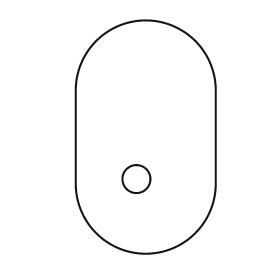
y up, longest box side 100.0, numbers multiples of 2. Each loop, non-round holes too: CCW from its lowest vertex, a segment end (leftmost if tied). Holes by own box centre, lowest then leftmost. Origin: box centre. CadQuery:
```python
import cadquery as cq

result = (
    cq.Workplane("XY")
    .moveTo(-30.0, -20.0)
    .threePointArc((0.0, -50.0), (30.0, -20.0))
    .lineTo(30.0, 20.0)
    .threePointArc((0.0, 50.0), (-30.0, 20.0))
    .close()
    .moveTo(-4.0, -18.0)
    .circle(6.0)
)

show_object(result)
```